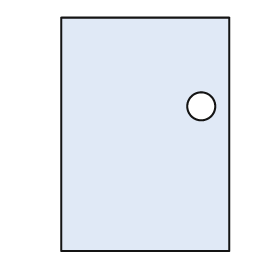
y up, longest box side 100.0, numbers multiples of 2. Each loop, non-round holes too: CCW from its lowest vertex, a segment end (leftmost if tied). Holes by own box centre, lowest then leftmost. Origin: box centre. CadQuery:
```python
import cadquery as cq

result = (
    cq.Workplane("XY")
    .moveTo(-36.0, -50.0)
    .lineTo(36.0, -50.0)
    .lineTo(36.0, 50.0)
    .lineTo(-36.0, 50.0)
    .close()
    .moveTo(24.0, 12.0)
    .circle(6.0)
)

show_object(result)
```